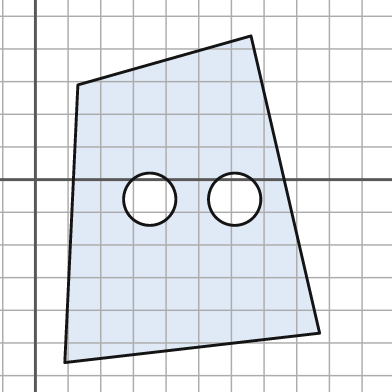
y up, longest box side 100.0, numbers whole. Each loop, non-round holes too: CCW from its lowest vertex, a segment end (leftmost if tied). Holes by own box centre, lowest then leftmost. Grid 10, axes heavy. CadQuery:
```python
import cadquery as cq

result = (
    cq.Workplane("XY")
    .moveTo(9.0, -56.0)
    .lineTo(87.0, -47.0)
    .lineTo(66.0, 44.0)
    .lineTo(13.0, 29.0)
    .close()
    .moveTo(35.0, -6.0)
    .circle(8.0)
    .moveTo(61.0, -6.0)
    .circle(8.0)
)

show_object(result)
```